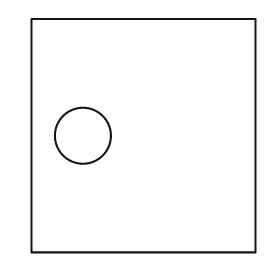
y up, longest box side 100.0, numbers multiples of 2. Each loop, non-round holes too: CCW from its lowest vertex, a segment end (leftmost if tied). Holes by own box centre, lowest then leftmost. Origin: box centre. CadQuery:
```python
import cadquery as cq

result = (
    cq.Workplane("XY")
    .moveTo(-48.0, -50.0)
    .lineTo(48.0, -50.0)
    .lineTo(48.0, 50.0)
    .lineTo(-48.0, 50.0)
    .close()
    .moveTo(-26.0, 0.0)
    .circle(12.0)
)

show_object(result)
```